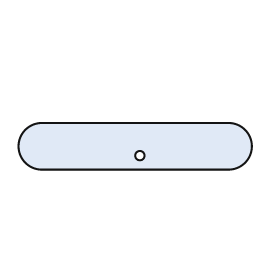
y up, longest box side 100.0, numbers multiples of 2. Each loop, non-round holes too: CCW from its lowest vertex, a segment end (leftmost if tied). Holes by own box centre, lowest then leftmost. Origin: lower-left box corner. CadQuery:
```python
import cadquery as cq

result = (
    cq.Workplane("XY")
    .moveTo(10.0, 0.0)
    .lineTo(90.0, 0.0)
    .threePointArc((100.0, 10.0), (90.0, 20.0))
    .lineTo(10.0, 20.0)
    .threePointArc((0.0, 10.0), (10.0, 0.0))
    .close()
    .moveTo(52.0, 6.0)
    .circle(2.0)
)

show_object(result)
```